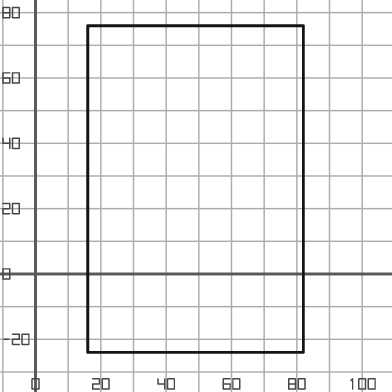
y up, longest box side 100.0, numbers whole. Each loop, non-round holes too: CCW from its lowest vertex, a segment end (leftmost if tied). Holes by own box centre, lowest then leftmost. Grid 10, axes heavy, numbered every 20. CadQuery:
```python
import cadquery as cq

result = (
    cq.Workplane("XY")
    .moveTo(16.0, -24.0)
    .lineTo(82.0, -24.0)
    .lineTo(82.0, 76.0)
    .lineTo(16.0, 76.0)
    .close()
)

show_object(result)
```